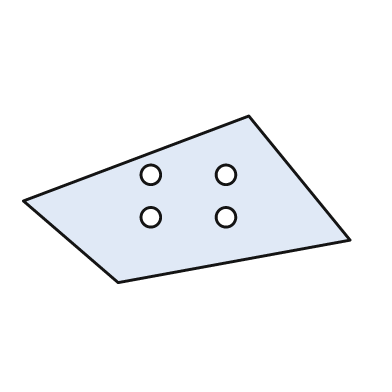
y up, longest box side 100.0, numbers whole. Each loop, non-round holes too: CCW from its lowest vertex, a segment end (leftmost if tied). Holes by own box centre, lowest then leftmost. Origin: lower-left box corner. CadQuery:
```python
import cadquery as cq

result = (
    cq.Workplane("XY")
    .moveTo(29.0, 0.0)
    .lineTo(100.0, 13.0)
    .lineTo(69.0, 51.0)
    .lineTo(0.0, 25.0)
    .close()
    .moveTo(39.0, 20.0)
    .circle(3.0)
    .moveTo(62.0, 20.0)
    .circle(3.0)
    .moveTo(39.0, 33.0)
    .circle(3.0)
    .moveTo(62.0, 33.0)
    .circle(3.0)
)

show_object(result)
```